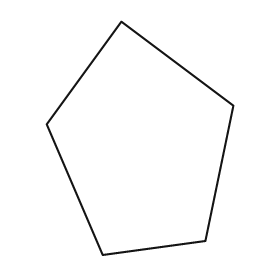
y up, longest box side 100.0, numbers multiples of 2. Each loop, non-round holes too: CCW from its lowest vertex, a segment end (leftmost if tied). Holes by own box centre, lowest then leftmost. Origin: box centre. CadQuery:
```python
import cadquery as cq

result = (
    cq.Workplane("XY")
    .moveTo(-16.0, -50.0)
    .lineTo(28.0, -44.0)
    .lineTo(40.0, 14.0)
    .lineTo(-8.0, 50.0)
    .lineTo(-40.0, 6.0)
    .close()
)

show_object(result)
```